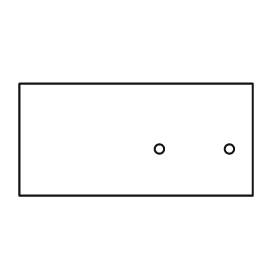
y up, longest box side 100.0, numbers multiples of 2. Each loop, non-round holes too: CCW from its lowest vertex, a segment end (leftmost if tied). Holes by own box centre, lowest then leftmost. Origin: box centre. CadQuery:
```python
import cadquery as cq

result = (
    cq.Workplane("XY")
    .moveTo(-50.0, -24.0)
    .lineTo(50.0, -24.0)
    .lineTo(50.0, 24.0)
    .lineTo(-50.0, 24.0)
    .close()
    .moveTo(10.0, -4.0)
    .circle(2.0)
    .moveTo(40.0, -4.0)
    .circle(2.0)
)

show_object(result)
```